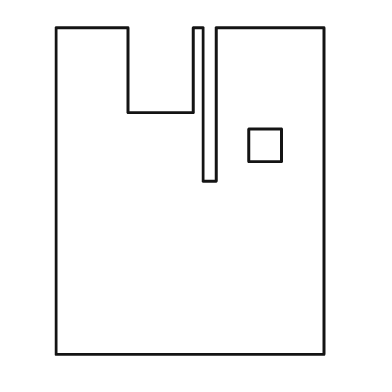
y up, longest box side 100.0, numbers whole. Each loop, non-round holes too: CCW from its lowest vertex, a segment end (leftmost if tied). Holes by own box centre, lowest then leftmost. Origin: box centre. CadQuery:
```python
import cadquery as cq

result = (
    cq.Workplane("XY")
    .moveTo(-41.0, -50.0)
    .lineTo(41.0, -50.0)
    .lineTo(41.0, 50.0)
    .lineTo(8.0, 50.0)
    .lineTo(8.0, 3.0)
    .lineTo(4.0, 3.0)
    .lineTo(4.0, 50.0)
    .lineTo(1.0, 50.0)
    .lineTo(1.0, 24.0)
    .lineTo(-19.0, 24.0)
    .lineTo(-19.0, 50.0)
    .lineTo(-41.0, 50.0)
    .close()
    .moveTo(18.0, 9.0)
    .lineTo(28.0, 9.0)
    .lineTo(28.0, 19.0)
    .lineTo(18.0, 19.0)
    .close()
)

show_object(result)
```